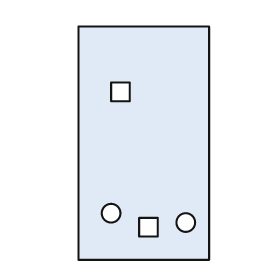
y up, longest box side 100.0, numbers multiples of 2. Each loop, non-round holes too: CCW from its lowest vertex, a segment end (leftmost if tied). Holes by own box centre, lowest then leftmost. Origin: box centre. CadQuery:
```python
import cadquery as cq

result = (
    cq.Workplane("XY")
    .moveTo(-28.0, -50.0)
    .lineTo(28.0, -50.0)
    .lineTo(28.0, 50.0)
    .lineTo(-28.0, 50.0)
    .close()
    .moveTo(-2.0, -40.0)
    .lineTo(6.0, -40.0)
    .lineTo(6.0, -32.0)
    .lineTo(-2.0, -32.0)
    .close()
    .moveTo(18.0, -34.0)
    .circle(4.0)
    .moveTo(-14.0, -30.0)
    .circle(4.0)
    .moveTo(-14.0, 18.0)
    .lineTo(-6.0, 18.0)
    .lineTo(-6.0, 26.0)
    .lineTo(-14.0, 26.0)
    .close()
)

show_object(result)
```